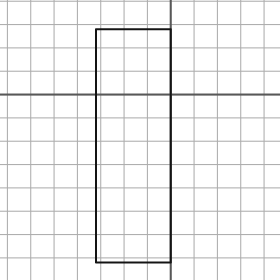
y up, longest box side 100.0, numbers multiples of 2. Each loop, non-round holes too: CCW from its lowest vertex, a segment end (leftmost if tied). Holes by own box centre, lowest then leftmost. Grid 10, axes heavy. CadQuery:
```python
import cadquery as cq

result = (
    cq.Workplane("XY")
    .moveTo(-32.0, -72.0)
    .lineTo(0.0, -72.0)
    .lineTo(0.0, 28.0)
    .lineTo(-32.0, 28.0)
    .close()
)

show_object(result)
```